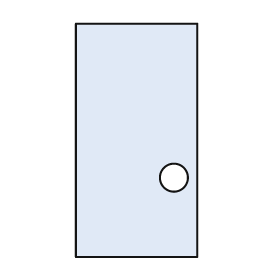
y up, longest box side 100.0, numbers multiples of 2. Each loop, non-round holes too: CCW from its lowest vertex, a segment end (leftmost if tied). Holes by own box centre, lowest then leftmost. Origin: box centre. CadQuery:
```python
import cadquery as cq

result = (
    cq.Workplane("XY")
    .moveTo(-26.0, -50.0)
    .lineTo(26.0, -50.0)
    .lineTo(26.0, 50.0)
    .lineTo(-26.0, 50.0)
    .close()
    .moveTo(16.0, -16.0)
    .circle(6.0)
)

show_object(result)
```